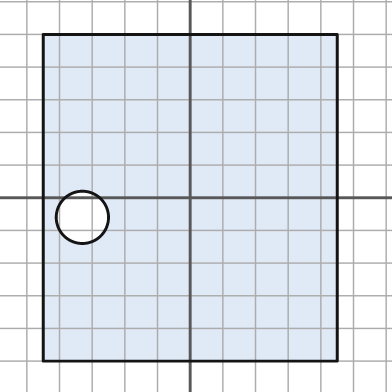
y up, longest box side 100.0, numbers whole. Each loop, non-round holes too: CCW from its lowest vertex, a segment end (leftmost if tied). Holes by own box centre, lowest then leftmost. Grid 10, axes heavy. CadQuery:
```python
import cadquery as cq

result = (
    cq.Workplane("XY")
    .moveTo(-45.0, -50.0)
    .lineTo(45.0, -50.0)
    .lineTo(45.0, 50.0)
    .lineTo(-45.0, 50.0)
    .close()
    .moveTo(-33.0, -6.0)
    .circle(8.0)
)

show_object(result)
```